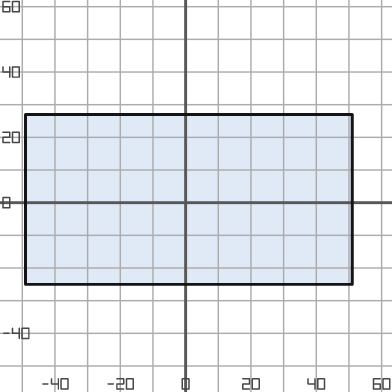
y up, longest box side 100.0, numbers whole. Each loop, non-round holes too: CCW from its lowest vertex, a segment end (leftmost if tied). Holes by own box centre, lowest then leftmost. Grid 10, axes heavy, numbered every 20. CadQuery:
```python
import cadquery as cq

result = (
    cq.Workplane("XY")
    .moveTo(-49.0, -25.0)
    .lineTo(51.0, -25.0)
    .lineTo(51.0, 27.0)
    .lineTo(-49.0, 27.0)
    .close()
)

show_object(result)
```